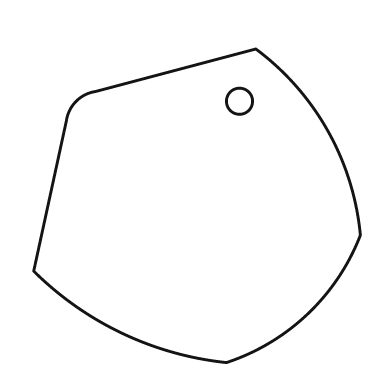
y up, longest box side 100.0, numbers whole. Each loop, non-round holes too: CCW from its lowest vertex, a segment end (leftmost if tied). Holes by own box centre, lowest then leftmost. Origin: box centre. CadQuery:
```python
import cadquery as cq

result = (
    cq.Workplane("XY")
    .moveTo(9.0, -48.0)
    .threePointArc((34.0, -33.0), (50.0, -9.0))
    .threePointArc((40.0, 23.0), (18.0, 48.0))
    .lineTo(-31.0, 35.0)
    .threePointArc((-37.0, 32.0), (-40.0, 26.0))
    .lineTo(-50.0, -20.0)
    .threePointArc((-23.0, -39.0), (9.0, -48.0))
    .close()
    .moveTo(13.0, 32.0)
    .circle(4.0)
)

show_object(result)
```